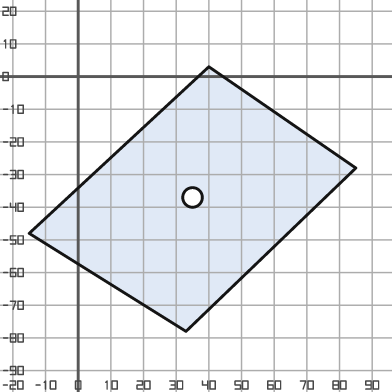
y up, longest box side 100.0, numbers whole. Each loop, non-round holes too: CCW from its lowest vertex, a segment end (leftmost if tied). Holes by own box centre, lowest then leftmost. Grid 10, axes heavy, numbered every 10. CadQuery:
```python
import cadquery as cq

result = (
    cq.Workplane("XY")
    .moveTo(33.0, -78.0)
    .lineTo(85.0, -28.0)
    .lineTo(40.0, 3.0)
    .lineTo(-15.0, -48.0)
    .close()
    .moveTo(35.0, -37.0)
    .circle(3.0)
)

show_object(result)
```